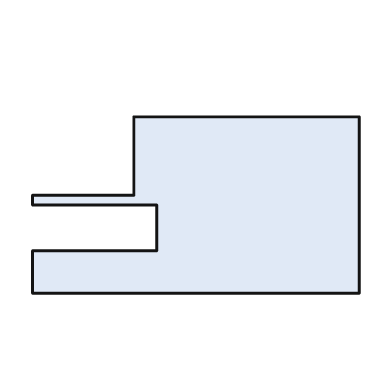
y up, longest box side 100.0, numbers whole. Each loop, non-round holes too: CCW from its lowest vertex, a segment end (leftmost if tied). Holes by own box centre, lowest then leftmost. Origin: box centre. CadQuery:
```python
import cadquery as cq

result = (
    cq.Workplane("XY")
    .moveTo(-50.0, -27.0)
    .lineTo(50.0, -27.0)
    .lineTo(50.0, 27.0)
    .lineTo(-19.0, 27.0)
    .lineTo(-19.0, 3.0)
    .lineTo(-50.0, 3.0)
    .lineTo(-50.0, 0.0)
    .lineTo(-12.0, 0.0)
    .lineTo(-12.0, -14.0)
    .lineTo(-50.0, -14.0)
    .close()
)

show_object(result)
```